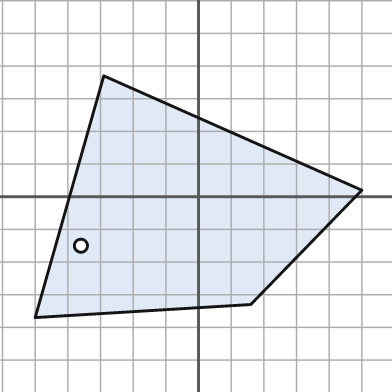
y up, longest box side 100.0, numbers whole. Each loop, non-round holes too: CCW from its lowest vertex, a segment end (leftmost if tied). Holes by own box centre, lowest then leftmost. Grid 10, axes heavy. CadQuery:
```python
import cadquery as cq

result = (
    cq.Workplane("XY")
    .moveTo(-50.0, -37.0)
    .lineTo(16.0, -33.0)
    .lineTo(50.0, 2.0)
    .lineTo(-29.0, 37.0)
    .close()
    .moveTo(-36.0, -15.0)
    .circle(2.0)
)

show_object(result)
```